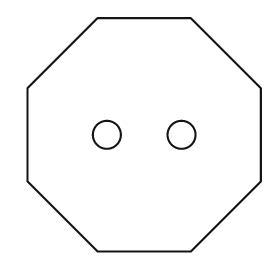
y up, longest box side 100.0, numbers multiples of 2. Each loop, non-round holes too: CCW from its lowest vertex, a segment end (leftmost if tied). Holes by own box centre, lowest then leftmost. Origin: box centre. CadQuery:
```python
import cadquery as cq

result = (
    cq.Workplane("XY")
    .moveTo(-20.0, -50.0)
    .lineTo(20.0, -50.0)
    .lineTo(50.0, -20.0)
    .lineTo(50.0, 20.0)
    .lineTo(20.0, 50.0)
    .lineTo(-20.0, 50.0)
    .lineTo(-50.0, 20.0)
    .lineTo(-50.0, -20.0)
    .close()
    .moveTo(-16.0, 0.0)
    .circle(6.0)
    .moveTo(16.0, 0.0)
    .circle(6.0)
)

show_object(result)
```